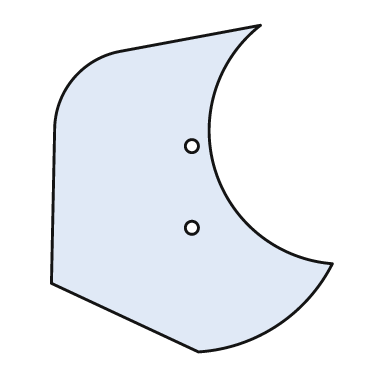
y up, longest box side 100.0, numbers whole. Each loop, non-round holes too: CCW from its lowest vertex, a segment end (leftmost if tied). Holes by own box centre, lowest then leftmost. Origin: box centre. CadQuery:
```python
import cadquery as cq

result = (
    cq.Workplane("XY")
    .moveTo(2.0, -50.0)
    .threePointArc((26.0, -42.0), (43.0, -23.0))
    .threePointArc((7.0, 6.0), (21.0, 50.0))
    .lineTo(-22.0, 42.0)
    .threePointArc((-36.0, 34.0), (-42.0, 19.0))
    .lineTo(-43.0, -29.0)
    .close()
    .moveTo(0.0, -12.0)
    .circle(2.0)
    .moveTo(0.0, 13.0)
    .circle(2.0)
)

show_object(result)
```